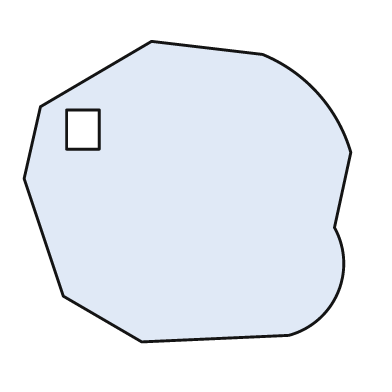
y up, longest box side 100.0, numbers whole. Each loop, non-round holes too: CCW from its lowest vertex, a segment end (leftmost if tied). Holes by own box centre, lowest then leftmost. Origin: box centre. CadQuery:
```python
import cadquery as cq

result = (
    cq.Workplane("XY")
    .moveTo(-14.0, -46.0)
    .lineTo(31.0, -44.0)
    .threePointArc((46.0, -31.0), (45.0, -11.0))
    .lineTo(50.0, 12.0)
    .threePointArc((40.0, 30.0), (23.0, 42.0))
    .lineTo(-11.0, 46.0)
    .lineTo(-45.0, 26.0)
    .lineTo(-50.0, 4.0)
    .lineTo(-38.0, -32.0)
    .close()
    .moveTo(-37.0, 13.0)
    .lineTo(-27.0, 13.0)
    .lineTo(-27.0, 25.0)
    .lineTo(-37.0, 25.0)
    .close()
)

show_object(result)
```